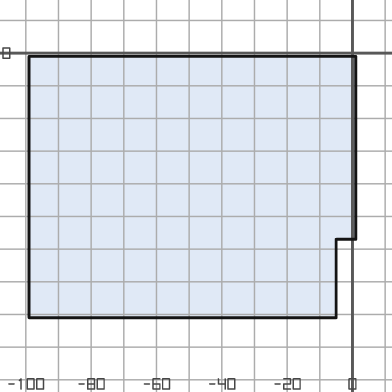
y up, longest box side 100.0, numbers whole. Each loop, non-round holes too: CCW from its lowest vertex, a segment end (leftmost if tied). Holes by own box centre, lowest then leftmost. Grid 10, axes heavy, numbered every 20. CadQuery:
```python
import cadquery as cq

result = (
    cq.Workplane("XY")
    .moveTo(-99.0, -81.0)
    .lineTo(-5.0, -81.0)
    .lineTo(-5.0, -57.0)
    .lineTo(1.0, -57.0)
    .lineTo(1.0, -1.0)
    .lineTo(-99.0, -1.0)
    .close()
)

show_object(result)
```